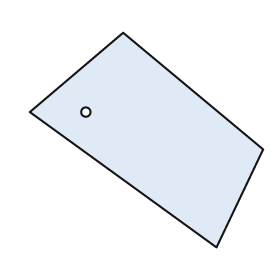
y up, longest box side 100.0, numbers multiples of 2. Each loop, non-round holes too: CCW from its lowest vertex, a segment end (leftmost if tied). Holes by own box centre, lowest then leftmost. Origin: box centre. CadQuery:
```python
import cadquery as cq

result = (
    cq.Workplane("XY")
    .moveTo(30.0, -46.0)
    .lineTo(50.0, -4.0)
    .lineTo(-10.0, 46.0)
    .lineTo(-50.0, 12.0)
    .close()
    .moveTo(-26.0, 12.0)
    .circle(2.0)
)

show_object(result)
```